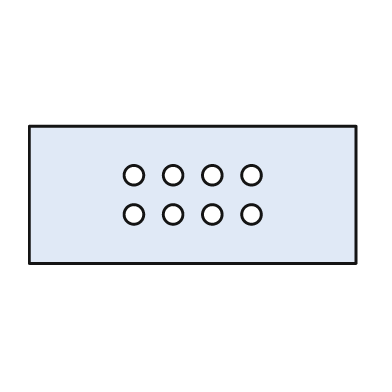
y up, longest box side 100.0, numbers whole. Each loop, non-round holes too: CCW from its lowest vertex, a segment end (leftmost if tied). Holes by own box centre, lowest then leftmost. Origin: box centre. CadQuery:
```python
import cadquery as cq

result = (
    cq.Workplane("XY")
    .moveTo(-50.0, -21.0)
    .lineTo(50.0, -21.0)
    .lineTo(50.0, 21.0)
    .lineTo(-50.0, 21.0)
    .close()
    .moveTo(-18.0, -6.0)
    .circle(3.0)
    .moveTo(-6.0, -6.0)
    .circle(3.0)
    .moveTo(6.0, -6.0)
    .circle(3.0)
    .moveTo(18.0, -6.0)
    .circle(3.0)
    .moveTo(-18.0, 6.0)
    .circle(3.0)
    .moveTo(-6.0, 6.0)
    .circle(3.0)
    .moveTo(6.0, 6.0)
    .circle(3.0)
    .moveTo(18.0, 6.0)
    .circle(3.0)
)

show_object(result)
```